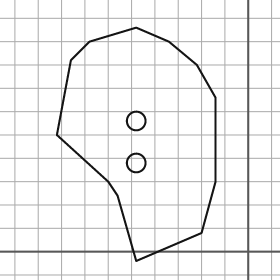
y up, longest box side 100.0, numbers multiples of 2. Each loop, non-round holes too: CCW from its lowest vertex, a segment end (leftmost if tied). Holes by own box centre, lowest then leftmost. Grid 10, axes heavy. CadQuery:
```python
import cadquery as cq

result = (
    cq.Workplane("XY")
    .moveTo(-48.0, -4.0)
    .lineTo(-20.0, 8.0)
    .lineTo(-14.0, 30.0)
    .lineTo(-14.0, 66.0)
    .lineTo(-22.0, 80.0)
    .lineTo(-34.0, 90.0)
    .lineTo(-48.0, 96.0)
    .lineTo(-68.0, 90.0)
    .lineTo(-76.0, 82.0)
    .lineTo(-82.0, 50.0)
    .lineTo(-60.0, 30.0)
    .lineTo(-56.0, 24.0)
    .close()
    .moveTo(-48.0, 38.0)
    .circle(4.0)
    .moveTo(-48.0, 56.0)
    .circle(4.0)
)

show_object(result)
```